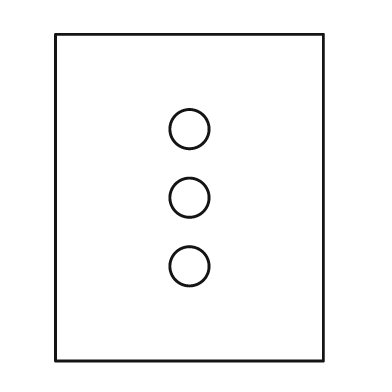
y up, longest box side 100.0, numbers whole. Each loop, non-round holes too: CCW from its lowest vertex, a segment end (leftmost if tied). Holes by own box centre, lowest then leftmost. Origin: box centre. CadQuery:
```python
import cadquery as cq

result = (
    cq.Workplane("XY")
    .moveTo(-41.0, -50.0)
    .lineTo(41.0, -50.0)
    .lineTo(41.0, 50.0)
    .lineTo(-41.0, 50.0)
    .close()
    .moveTo(0.0, -21.0)
    .circle(6.0)
    .moveTo(0.0, 0.0)
    .circle(6.0)
    .moveTo(0.0, 21.0)
    .circle(6.0)
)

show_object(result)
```